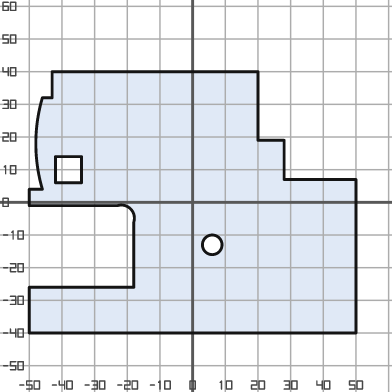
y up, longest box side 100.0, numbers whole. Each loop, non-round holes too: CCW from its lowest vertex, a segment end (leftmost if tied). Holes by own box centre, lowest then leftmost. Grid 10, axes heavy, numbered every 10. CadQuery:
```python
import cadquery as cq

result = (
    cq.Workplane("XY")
    .moveTo(-50.0, -40.0)
    .lineTo(50.0, -40.0)
    .lineTo(50.0, 7.0)
    .lineTo(28.0, 7.0)
    .lineTo(28.0, 19.0)
    .lineTo(20.0, 19.0)
    .lineTo(20.0, 40.0)
    .lineTo(-43.0, 40.0)
    .lineTo(-43.0, 32.0)
    .lineTo(-46.0, 32.0)
    .threePointArc((-48.0, 18.0), (-46.0, 4.0))
    .lineTo(-50.0, 4.0)
    .lineTo(-50.0, -1.0)
    .lineTo(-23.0, -1.0)
    .threePointArc((-19.0, -2.0), (-18.0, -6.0))
    .lineTo(-18.0, -26.0)
    .lineTo(-50.0, -26.0)
    .close()
    .moveTo(6.0, -13.0)
    .circle(3.0)
    .moveTo(-42.0, 6.0)
    .lineTo(-34.0, 6.0)
    .lineTo(-34.0, 14.0)
    .lineTo(-42.0, 14.0)
    .close()
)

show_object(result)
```